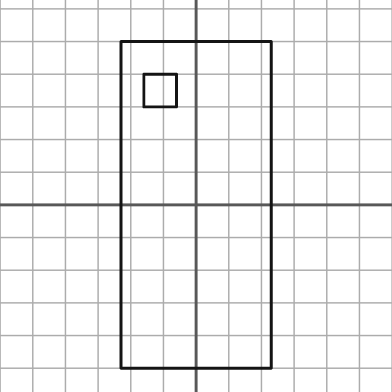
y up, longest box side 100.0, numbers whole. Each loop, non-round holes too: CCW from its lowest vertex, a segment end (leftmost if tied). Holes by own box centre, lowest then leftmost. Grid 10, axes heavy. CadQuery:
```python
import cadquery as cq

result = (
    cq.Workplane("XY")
    .moveTo(-23.0, -50.0)
    .lineTo(23.0, -50.0)
    .lineTo(23.0, 50.0)
    .lineTo(-23.0, 50.0)
    .close()
    .moveTo(-16.0, 30.0)
    .lineTo(-6.0, 30.0)
    .lineTo(-6.0, 40.0)
    .lineTo(-16.0, 40.0)
    .close()
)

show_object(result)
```